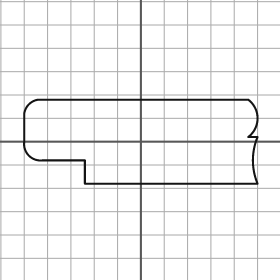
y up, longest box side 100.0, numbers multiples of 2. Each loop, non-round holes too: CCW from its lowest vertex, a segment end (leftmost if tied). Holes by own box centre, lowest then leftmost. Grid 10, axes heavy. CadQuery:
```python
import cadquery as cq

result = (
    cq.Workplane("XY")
    .moveTo(-24.0, -18.0)
    .lineTo(50.0, -18.0)
    .threePointArc((48.0, -8.0), (50.0, 2.0))
    .lineTo(46.0, 2.0)
    .threePointArc((50.0, 10.0), (46.0, 18.0))
    .lineTo(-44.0, 18.0)
    .threePointArc((-48.0, 16.0), (-50.0, 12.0))
    .lineTo(-50.0, 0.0)
    .threePointArc((-48.0, -6.0), (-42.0, -8.0))
    .lineTo(-24.0, -8.0)
    .close()
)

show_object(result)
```